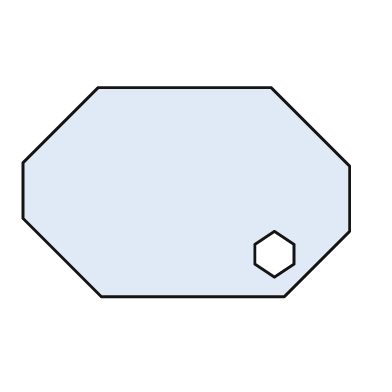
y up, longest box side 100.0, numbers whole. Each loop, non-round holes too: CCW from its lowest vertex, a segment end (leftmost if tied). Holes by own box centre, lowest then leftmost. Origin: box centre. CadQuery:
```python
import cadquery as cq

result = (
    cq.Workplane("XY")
    .moveTo(-26.0, -32.0)
    .lineTo(30.0, -32.0)
    .lineTo(50.0, -12.0)
    .lineTo(50.0, 8.0)
    .lineTo(26.0, 32.0)
    .lineTo(-27.0, 32.0)
    .lineTo(-50.0, 9.0)
    .lineTo(-50.0, -8.0)
    .close()
    .moveTo(27.0, -26.0)
    .lineTo(33.0, -22.0)
    .lineTo(33.0, -16.0)
    .lineTo(27.0, -12.0)
    .lineTo(21.0, -16.0)
    .lineTo(21.0, -22.0)
    .close()
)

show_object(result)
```